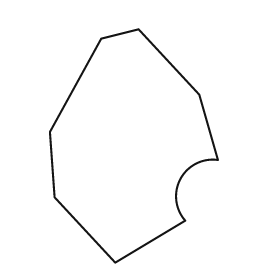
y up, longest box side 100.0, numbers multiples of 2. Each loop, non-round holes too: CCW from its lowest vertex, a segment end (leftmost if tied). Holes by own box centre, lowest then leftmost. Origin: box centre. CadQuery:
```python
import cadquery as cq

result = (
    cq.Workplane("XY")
    .moveTo(-8.0, -50.0)
    .lineTo(22.0, -32.0)
    .threePointArc((20.0, -14.0), (36.0, -6.0))
    .lineTo(28.0, 22.0)
    .lineTo(2.0, 50.0)
    .lineTo(-14.0, 46.0)
    .lineTo(-36.0, 6.0)
    .lineTo(-34.0, -22.0)
    .close()
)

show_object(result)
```